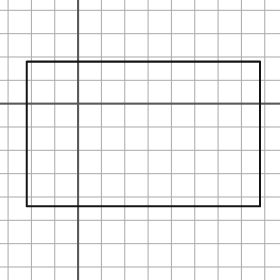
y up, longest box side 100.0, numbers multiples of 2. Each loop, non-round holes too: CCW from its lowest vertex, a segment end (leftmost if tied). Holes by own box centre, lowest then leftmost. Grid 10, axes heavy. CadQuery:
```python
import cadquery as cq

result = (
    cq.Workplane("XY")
    .moveTo(-22.0, -44.0)
    .lineTo(78.0, -44.0)
    .lineTo(78.0, 18.0)
    .lineTo(-22.0, 18.0)
    .close()
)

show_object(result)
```